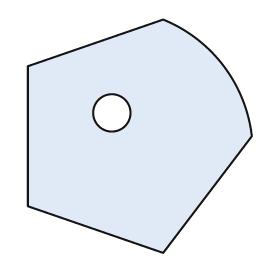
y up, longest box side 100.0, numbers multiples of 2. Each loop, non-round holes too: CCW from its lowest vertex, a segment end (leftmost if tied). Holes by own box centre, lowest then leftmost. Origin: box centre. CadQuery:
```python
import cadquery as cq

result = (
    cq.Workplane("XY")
    .moveTo(10.0, -50.0)
    .lineTo(48.0, 0.0)
    .threePointArc((36.0, 30.0), (10.0, 50.0))
    .lineTo(-48.0, 30.0)
    .lineTo(-48.0, -30.0)
    .close()
    .moveTo(-12.0, 10.0)
    .circle(8.0)
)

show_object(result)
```